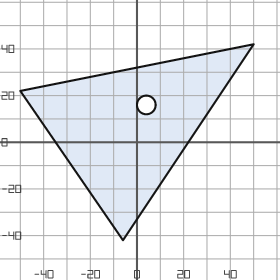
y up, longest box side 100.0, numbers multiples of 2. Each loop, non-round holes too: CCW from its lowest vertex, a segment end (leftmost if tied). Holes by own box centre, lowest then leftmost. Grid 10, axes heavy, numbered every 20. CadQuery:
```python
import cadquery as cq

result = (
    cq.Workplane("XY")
    .moveTo(-6.0, -42.0)
    .lineTo(50.0, 42.0)
    .lineTo(-50.0, 22.0)
    .close()
    .moveTo(4.0, 16.0)
    .circle(4.0)
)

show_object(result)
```